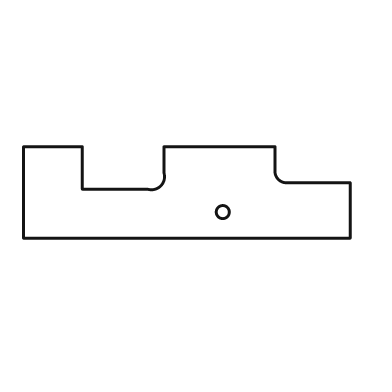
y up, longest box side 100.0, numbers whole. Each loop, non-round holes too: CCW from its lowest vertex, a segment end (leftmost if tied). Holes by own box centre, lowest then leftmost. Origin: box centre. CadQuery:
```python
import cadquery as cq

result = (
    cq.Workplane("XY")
    .moveTo(-50.0, -14.0)
    .lineTo(50.0, -14.0)
    .lineTo(50.0, 3.0)
    .lineTo(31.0, 3.0)
    .threePointArc((28.0, 4.0), (27.0, 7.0))
    .lineTo(27.0, 14.0)
    .lineTo(-7.0, 14.0)
    .lineTo(-7.0, 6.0)
    .threePointArc((-8.0, 2.0), (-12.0, 1.0))
    .lineTo(-32.0, 1.0)
    .lineTo(-32.0, 14.0)
    .lineTo(-50.0, 14.0)
    .close()
    .moveTo(11.0, -6.0)
    .circle(2.0)
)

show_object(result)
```